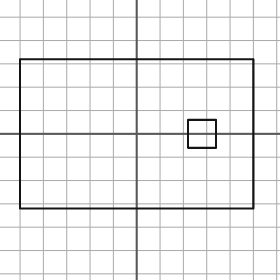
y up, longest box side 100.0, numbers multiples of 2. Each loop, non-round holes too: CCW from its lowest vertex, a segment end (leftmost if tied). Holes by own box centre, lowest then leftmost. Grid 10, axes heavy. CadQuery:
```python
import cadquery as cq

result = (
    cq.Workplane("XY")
    .moveTo(-50.0, -32.0)
    .lineTo(50.0, -32.0)
    .lineTo(50.0, 32.0)
    .lineTo(-50.0, 32.0)
    .close()
    .moveTo(22.0, -6.0)
    .lineTo(34.0, -6.0)
    .lineTo(34.0, 6.0)
    .lineTo(22.0, 6.0)
    .close()
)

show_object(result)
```